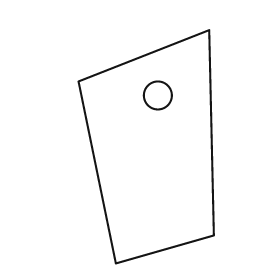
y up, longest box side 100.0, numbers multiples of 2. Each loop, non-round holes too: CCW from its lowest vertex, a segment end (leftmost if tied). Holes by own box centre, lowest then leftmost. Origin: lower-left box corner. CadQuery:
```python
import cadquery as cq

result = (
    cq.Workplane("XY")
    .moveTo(16.0, 0.0)
    .lineTo(58.0, 12.0)
    .lineTo(56.0, 100.0)
    .lineTo(0.0, 78.0)
    .close()
    .moveTo(34.0, 72.0)
    .circle(6.0)
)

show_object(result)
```